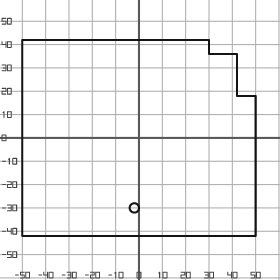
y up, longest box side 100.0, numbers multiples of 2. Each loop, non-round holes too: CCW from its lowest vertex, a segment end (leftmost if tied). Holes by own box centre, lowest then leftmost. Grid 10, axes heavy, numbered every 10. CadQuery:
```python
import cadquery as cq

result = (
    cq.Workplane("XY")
    .moveTo(-50.0, -42.0)
    .lineTo(50.0, -42.0)
    .lineTo(50.0, 18.0)
    .lineTo(42.0, 18.0)
    .lineTo(42.0, 36.0)
    .lineTo(30.0, 36.0)
    .lineTo(30.0, 42.0)
    .lineTo(-50.0, 42.0)
    .close()
    .moveTo(-2.0, -30.0)
    .circle(2.0)
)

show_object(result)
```